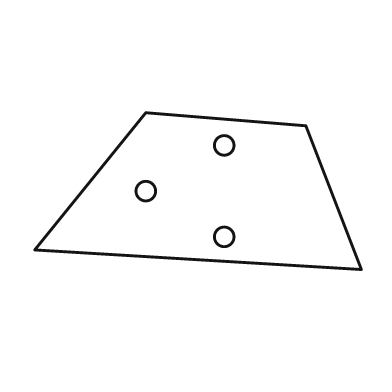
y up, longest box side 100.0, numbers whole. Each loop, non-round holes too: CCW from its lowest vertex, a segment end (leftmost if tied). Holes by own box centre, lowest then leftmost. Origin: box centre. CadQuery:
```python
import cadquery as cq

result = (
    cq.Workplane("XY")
    .moveTo(50.0, -24.0)
    .lineTo(33.0, 20.0)
    .lineTo(-16.0, 24.0)
    .lineTo(-50.0, -18.0)
    .close()
    .moveTo(8.0, -14.0)
    .circle(3.0)
    .moveTo(-16.0, 0.0)
    .circle(3.0)
    .moveTo(8.0, 14.0)
    .circle(3.0)
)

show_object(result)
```